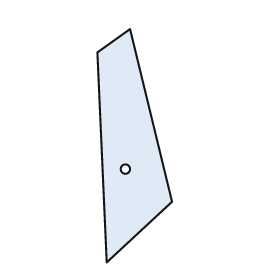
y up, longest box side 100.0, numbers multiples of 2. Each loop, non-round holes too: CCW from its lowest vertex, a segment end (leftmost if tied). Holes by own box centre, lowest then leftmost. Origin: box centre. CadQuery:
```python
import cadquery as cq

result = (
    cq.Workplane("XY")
    .moveTo(-12.0, -50.0)
    .lineTo(16.0, -24.0)
    .lineTo(-2.0, 50.0)
    .lineTo(-16.0, 40.0)
    .close()
    .moveTo(-4.0, -10.0)
    .circle(2.0)
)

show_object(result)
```